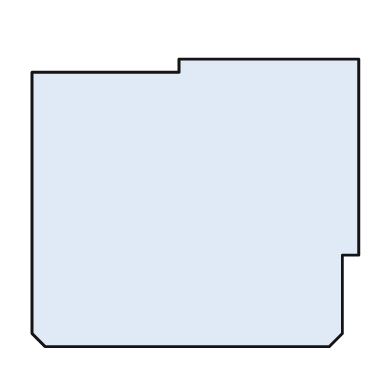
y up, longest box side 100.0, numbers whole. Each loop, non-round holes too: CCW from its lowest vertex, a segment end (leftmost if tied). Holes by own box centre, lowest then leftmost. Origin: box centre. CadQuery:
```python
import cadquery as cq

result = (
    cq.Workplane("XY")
    .moveTo(-46.0, -44.0)
    .lineTo(41.0, -44.0)
    .lineTo(45.0, -40.0)
    .lineTo(45.0, -16.0)
    .lineTo(50.0, -16.0)
    .lineTo(50.0, 44.0)
    .lineTo(-5.0, 44.0)
    .lineTo(-5.0, 40.0)
    .lineTo(-50.0, 40.0)
    .lineTo(-50.0, -40.0)
    .close()
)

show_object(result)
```